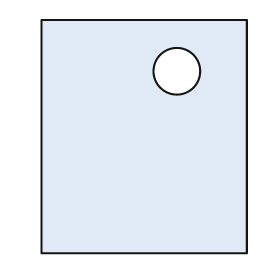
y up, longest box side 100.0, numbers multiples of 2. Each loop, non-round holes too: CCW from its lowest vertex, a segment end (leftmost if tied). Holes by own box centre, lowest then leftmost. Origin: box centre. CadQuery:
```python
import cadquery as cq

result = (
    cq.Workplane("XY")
    .moveTo(-44.0, -50.0)
    .lineTo(44.0, -50.0)
    .lineTo(44.0, 50.0)
    .lineTo(-44.0, 50.0)
    .close()
    .moveTo(14.0, 28.0)
    .circle(10.0)
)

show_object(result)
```